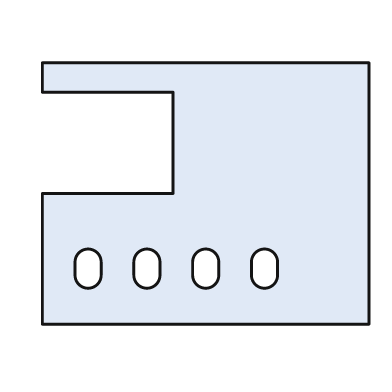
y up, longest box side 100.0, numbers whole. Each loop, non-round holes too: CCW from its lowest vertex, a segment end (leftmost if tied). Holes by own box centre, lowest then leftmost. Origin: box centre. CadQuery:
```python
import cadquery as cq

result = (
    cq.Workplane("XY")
    .moveTo(-50.0, -40.0)
    .lineTo(50.0, -40.0)
    .lineTo(50.0, 40.0)
    .lineTo(-50.0, 40.0)
    .lineTo(-50.0, 31.0)
    .lineTo(-10.0, 31.0)
    .lineTo(-10.0, 0.0)
    .lineTo(-50.0, 0.0)
    .close()
    .moveTo(-40.0, -25.0)
    .threePointArc((-36.0, -29.0), (-32.0, -25.0))
    .lineTo(-32.0, -21.0)
    .threePointArc((-36.0, -17.0), (-40.0, -21.0))
    .close()
    .moveTo(-22.0, -25.0)
    .threePointArc((-18.0, -29.0), (-14.0, -25.0))
    .lineTo(-14.0, -21.0)
    .threePointArc((-18.0, -17.0), (-22.0, -21.0))
    .close()
    .moveTo(-4.0, -25.0)
    .threePointArc((0.0, -29.0), (4.0, -25.0))
    .lineTo(4.0, -21.0)
    .threePointArc((0.0, -17.0), (-4.0, -21.0))
    .close()
    .moveTo(14.0, -25.0)
    .threePointArc((18.0, -29.0), (22.0, -25.0))
    .lineTo(22.0, -21.0)
    .threePointArc((18.0, -17.0), (14.0, -21.0))
    .close()
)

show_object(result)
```